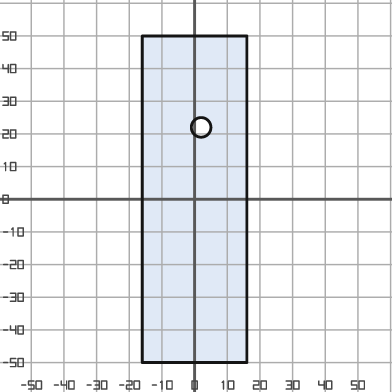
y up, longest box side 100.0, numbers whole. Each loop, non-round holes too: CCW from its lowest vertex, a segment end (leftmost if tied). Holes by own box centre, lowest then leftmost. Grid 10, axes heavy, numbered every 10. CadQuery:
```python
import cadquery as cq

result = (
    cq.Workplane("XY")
    .moveTo(-16.0, -50.0)
    .lineTo(16.0, -50.0)
    .lineTo(16.0, 50.0)
    .lineTo(-16.0, 50.0)
    .close()
    .moveTo(2.0, 22.0)
    .circle(3.0)
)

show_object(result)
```